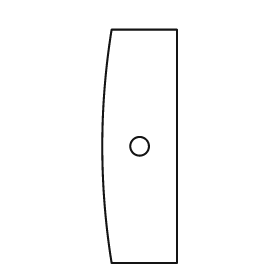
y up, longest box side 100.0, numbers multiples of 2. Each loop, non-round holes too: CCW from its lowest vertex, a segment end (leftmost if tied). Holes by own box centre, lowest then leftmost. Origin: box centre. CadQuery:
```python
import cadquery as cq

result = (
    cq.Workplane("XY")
    .moveTo(-12.0, -50.0)
    .lineTo(16.0, -50.0)
    .lineTo(16.0, 50.0)
    .lineTo(-12.0, 50.0)
    .threePointArc((-16.0, 0.0), (-12.0, -50.0))
    .close()
    .moveTo(0.0, 0.0)
    .circle(4.0)
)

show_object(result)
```